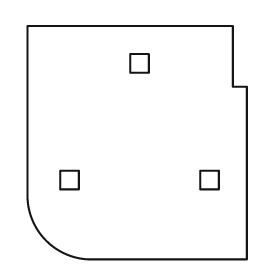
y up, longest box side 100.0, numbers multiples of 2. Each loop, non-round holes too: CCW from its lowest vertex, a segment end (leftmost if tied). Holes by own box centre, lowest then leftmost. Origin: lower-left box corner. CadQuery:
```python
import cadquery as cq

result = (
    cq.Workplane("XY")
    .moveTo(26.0, 0.0)
    .lineTo(94.0, 0.0)
    .lineTo(94.0, 74.0)
    .lineTo(88.0, 74.0)
    .lineTo(88.0, 100.0)
    .lineTo(0.0, 100.0)
    .lineTo(0.0, 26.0)
    .threePointArc((8.0, 8.0), (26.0, 0.0))
    .close()
    .moveTo(14.0, 30.0)
    .lineTo(22.0, 30.0)
    .lineTo(22.0, 38.0)
    .lineTo(14.0, 38.0)
    .close()
    .moveTo(74.0, 30.0)
    .lineTo(82.0, 30.0)
    .lineTo(82.0, 38.0)
    .lineTo(74.0, 38.0)
    .close()
    .moveTo(44.0, 80.0)
    .lineTo(52.0, 80.0)
    .lineTo(52.0, 88.0)
    .lineTo(44.0, 88.0)
    .close()
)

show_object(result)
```